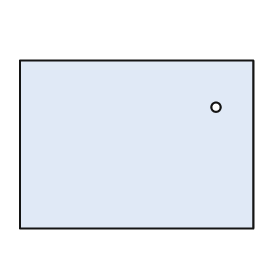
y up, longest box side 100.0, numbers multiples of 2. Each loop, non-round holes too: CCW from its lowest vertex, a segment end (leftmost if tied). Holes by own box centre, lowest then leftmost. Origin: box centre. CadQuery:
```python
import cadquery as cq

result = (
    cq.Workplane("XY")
    .moveTo(-50.0, -36.0)
    .lineTo(50.0, -36.0)
    .lineTo(50.0, 36.0)
    .lineTo(-50.0, 36.0)
    .close()
    .moveTo(34.0, 16.0)
    .circle(2.0)
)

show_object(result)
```